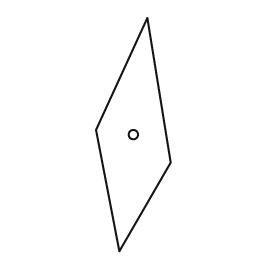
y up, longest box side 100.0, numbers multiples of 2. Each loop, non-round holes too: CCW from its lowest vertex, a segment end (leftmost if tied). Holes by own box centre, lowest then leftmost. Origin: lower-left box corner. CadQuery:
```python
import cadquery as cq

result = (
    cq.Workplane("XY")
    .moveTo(10.0, 0.0)
    .lineTo(32.0, 38.0)
    .lineTo(22.0, 100.0)
    .lineTo(0.0, 52.0)
    .close()
    .moveTo(16.0, 50.0)
    .circle(2.0)
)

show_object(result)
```